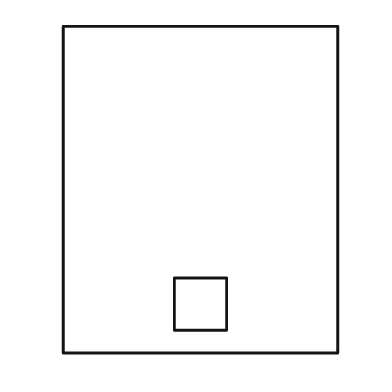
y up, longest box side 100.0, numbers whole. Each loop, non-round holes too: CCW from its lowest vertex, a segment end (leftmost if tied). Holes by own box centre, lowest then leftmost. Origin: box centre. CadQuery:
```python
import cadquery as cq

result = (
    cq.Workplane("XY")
    .moveTo(-42.0, -50.0)
    .lineTo(42.0, -50.0)
    .lineTo(42.0, 50.0)
    .lineTo(-42.0, 50.0)
    .close()
    .moveTo(-8.0, -43.0)
    .lineTo(8.0, -43.0)
    .lineTo(8.0, -27.0)
    .lineTo(-8.0, -27.0)
    .close()
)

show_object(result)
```